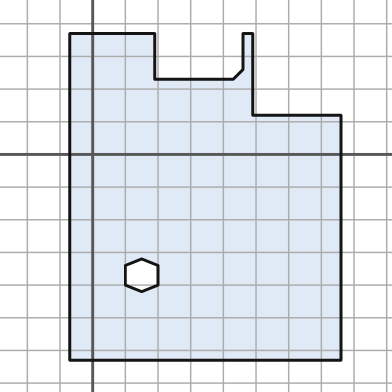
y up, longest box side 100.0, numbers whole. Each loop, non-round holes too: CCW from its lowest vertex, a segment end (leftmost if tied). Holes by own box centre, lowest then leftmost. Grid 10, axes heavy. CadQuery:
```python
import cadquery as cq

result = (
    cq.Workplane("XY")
    .moveTo(-7.0, -63.0)
    .lineTo(76.0, -63.0)
    .lineTo(76.0, 12.0)
    .lineTo(49.0, 12.0)
    .lineTo(49.0, 37.0)
    .lineTo(46.0, 37.0)
    .lineTo(46.0, 26.0)
    .lineTo(43.0, 23.0)
    .lineTo(19.0, 23.0)
    .lineTo(19.0, 37.0)
    .lineTo(-7.0, 37.0)
    .close()
    .moveTo(15.0, -42.0)
    .lineTo(20.0, -40.0)
    .lineTo(20.0, -34.0)
    .lineTo(15.0, -32.0)
    .lineTo(10.0, -34.0)
    .lineTo(10.0, -40.0)
    .close()
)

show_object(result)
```